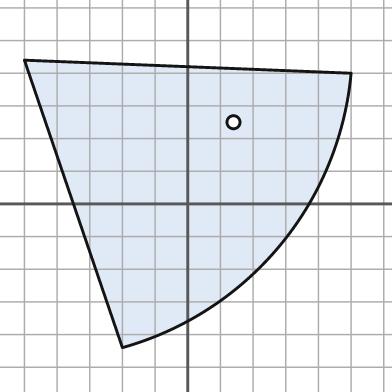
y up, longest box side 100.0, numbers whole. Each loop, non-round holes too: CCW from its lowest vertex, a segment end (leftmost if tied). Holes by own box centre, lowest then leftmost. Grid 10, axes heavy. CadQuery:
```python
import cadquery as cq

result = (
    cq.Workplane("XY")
    .moveTo(-20.0, -44.0)
    .threePointArc((28.0, -13.0), (50.0, 40.0))
    .lineTo(-50.0, 44.0)
    .close()
    .moveTo(14.0, 25.0)
    .circle(2.0)
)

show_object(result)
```